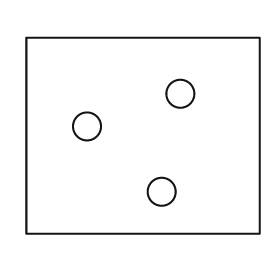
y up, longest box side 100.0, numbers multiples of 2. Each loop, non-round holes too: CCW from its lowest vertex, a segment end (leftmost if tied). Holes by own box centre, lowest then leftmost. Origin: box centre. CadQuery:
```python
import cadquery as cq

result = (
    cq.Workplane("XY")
    .moveTo(-50.0, -42.0)
    .lineTo(50.0, -42.0)
    .lineTo(50.0, 42.0)
    .lineTo(-50.0, 42.0)
    .close()
    .moveTo(8.0, -24.0)
    .circle(6.0)
    .moveTo(-24.0, 4.0)
    .circle(6.0)
    .moveTo(16.0, 18.0)
    .circle(6.0)
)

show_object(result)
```